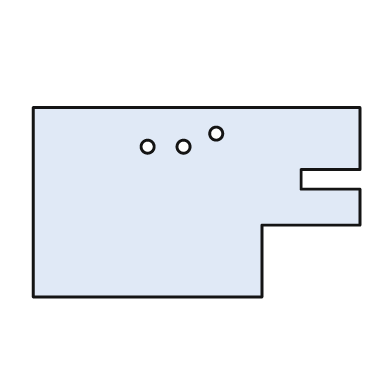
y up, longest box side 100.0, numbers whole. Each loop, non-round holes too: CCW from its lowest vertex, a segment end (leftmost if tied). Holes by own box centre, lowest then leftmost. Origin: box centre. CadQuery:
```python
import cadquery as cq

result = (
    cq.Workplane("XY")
    .moveTo(-50.0, -29.0)
    .lineTo(20.0, -29.0)
    .lineTo(20.0, -7.0)
    .lineTo(50.0, -7.0)
    .lineTo(50.0, 4.0)
    .lineTo(32.0, 4.0)
    .lineTo(32.0, 10.0)
    .lineTo(50.0, 10.0)
    .lineTo(50.0, 29.0)
    .lineTo(-50.0, 29.0)
    .close()
    .moveTo(-15.0, 17.0)
    .circle(2.0)
    .moveTo(-4.0, 17.0)
    .circle(2.0)
    .moveTo(6.0, 21.0)
    .circle(2.0)
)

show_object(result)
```